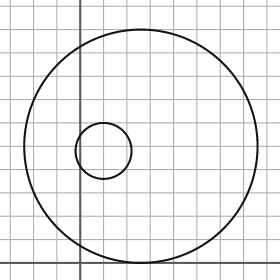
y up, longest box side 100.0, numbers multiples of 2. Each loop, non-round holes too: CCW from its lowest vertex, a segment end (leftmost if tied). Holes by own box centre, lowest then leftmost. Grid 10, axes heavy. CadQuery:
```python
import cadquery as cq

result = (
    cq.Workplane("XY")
    .moveTo(26.0, 50.0)
    .circle(50.0)
    .moveTo(10.0, 48.0)
    .circle(12.0)
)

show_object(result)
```